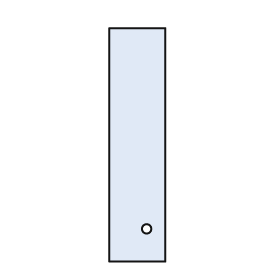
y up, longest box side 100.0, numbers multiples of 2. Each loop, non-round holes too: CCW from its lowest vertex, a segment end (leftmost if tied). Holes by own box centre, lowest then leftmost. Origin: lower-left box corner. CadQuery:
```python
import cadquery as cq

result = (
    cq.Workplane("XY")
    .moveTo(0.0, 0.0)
    .lineTo(24.0, 0.0)
    .lineTo(24.0, 100.0)
    .lineTo(0.0, 100.0)
    .close()
    .moveTo(16.0, 14.0)
    .circle(2.0)
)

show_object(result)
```